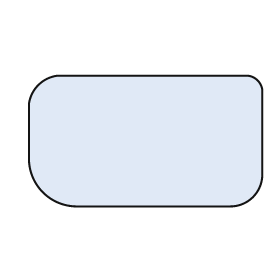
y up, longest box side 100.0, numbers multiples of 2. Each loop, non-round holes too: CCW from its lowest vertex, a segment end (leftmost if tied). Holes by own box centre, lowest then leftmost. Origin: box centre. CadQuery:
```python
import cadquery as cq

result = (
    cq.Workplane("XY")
    .moveTo(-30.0, -28.0)
    .lineTo(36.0, -28.0)
    .threePointArc((46.0, -24.0), (50.0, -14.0))
    .lineTo(50.0, 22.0)
    .threePointArc((48.0, 26.0), (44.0, 28.0))
    .lineTo(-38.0, 28.0)
    .threePointArc((-46.0, 24.0), (-50.0, 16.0))
    .lineTo(-50.0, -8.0)
    .threePointArc((-44.0, -22.0), (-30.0, -28.0))
    .close()
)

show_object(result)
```